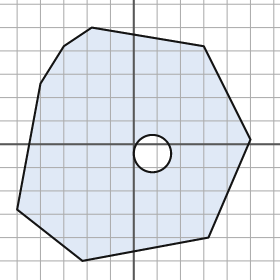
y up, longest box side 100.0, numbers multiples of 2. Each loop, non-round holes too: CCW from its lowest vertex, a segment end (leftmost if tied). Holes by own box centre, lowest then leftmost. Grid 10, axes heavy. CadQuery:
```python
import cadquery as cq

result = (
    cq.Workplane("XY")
    .moveTo(-22.0, -50.0)
    .lineTo(32.0, -40.0)
    .lineTo(50.0, 2.0)
    .lineTo(30.0, 42.0)
    .lineTo(-18.0, 50.0)
    .lineTo(-30.0, 42.0)
    .lineTo(-40.0, 26.0)
    .lineTo(-50.0, -28.0)
    .close()
    .moveTo(8.0, -4.0)
    .circle(8.0)
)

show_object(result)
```